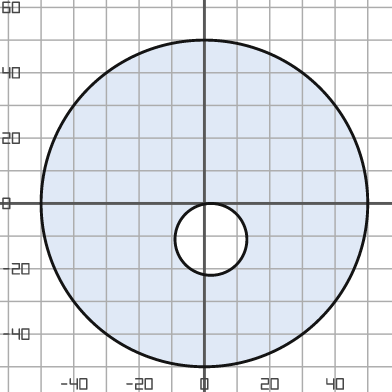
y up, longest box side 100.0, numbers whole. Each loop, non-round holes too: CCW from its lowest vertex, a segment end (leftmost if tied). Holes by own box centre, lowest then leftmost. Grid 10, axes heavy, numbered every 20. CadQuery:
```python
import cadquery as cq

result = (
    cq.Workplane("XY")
    .moveTo(0.0, 0.0)
    .circle(50.0)
    .moveTo(2.0, -11.0)
    .circle(11.0)
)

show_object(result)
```